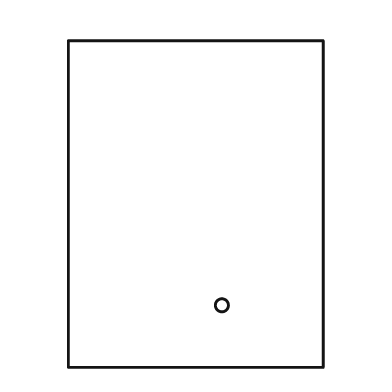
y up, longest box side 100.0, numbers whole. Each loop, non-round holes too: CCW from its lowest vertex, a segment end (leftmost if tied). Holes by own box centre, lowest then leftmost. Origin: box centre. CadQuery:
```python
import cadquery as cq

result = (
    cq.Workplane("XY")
    .moveTo(-39.0, -50.0)
    .lineTo(39.0, -50.0)
    .lineTo(39.0, 50.0)
    .lineTo(-39.0, 50.0)
    .close()
    .moveTo(8.0, -31.0)
    .circle(2.0)
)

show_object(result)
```